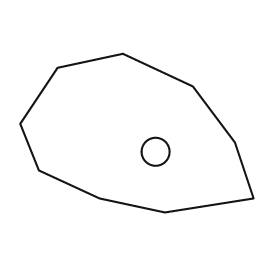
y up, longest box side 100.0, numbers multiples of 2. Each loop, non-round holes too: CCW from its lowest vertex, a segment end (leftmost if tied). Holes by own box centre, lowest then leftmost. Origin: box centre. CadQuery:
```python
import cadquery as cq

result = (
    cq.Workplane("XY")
    .moveTo(12.0, -34.0)
    .lineTo(50.0, -28.0)
    .lineTo(42.0, -4.0)
    .lineTo(24.0, 20.0)
    .lineTo(-6.0, 34.0)
    .lineTo(-34.0, 28.0)
    .lineTo(-50.0, 4.0)
    .lineTo(-42.0, -16.0)
    .lineTo(-16.0, -28.0)
    .close()
    .moveTo(8.0, -8.0)
    .circle(6.0)
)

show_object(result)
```